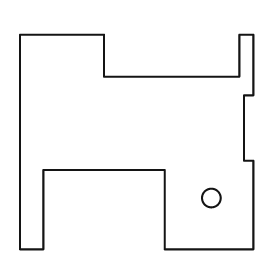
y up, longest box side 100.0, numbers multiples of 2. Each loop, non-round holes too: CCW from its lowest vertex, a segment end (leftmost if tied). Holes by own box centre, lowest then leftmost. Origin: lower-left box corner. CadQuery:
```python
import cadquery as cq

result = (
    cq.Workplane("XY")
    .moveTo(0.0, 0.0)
    .lineTo(10.0, 0.0)
    .lineTo(10.0, 34.0)
    .lineTo(62.0, 34.0)
    .lineTo(62.0, 0.0)
    .lineTo(100.0, 0.0)
    .lineTo(100.0, 38.0)
    .lineTo(96.0, 38.0)
    .lineTo(96.0, 66.0)
    .lineTo(100.0, 66.0)
    .lineTo(100.0, 92.0)
    .lineTo(94.0, 92.0)
    .lineTo(94.0, 74.0)
    .lineTo(36.0, 74.0)
    .lineTo(36.0, 92.0)
    .lineTo(0.0, 92.0)
    .close()
    .moveTo(82.0, 22.0)
    .circle(4.0)
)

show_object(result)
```